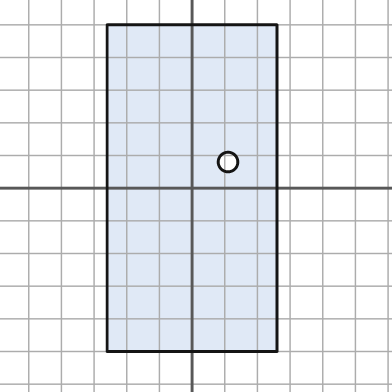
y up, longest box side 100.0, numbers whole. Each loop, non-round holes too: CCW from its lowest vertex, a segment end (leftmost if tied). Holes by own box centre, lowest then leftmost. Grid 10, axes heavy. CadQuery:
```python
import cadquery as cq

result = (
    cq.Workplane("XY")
    .moveTo(-26.0, -50.0)
    .lineTo(26.0, -50.0)
    .lineTo(26.0, 50.0)
    .lineTo(-26.0, 50.0)
    .close()
    .moveTo(11.0, 8.0)
    .circle(3.0)
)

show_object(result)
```